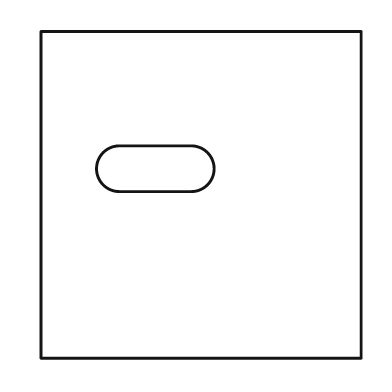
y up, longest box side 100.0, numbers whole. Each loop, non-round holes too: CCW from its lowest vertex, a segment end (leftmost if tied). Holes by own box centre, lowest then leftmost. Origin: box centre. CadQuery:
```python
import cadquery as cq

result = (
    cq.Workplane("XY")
    .moveTo(-49.0, -50.0)
    .lineTo(49.0, -50.0)
    .lineTo(49.0, 50.0)
    .lineTo(-49.0, 50.0)
    .close()
    .moveTo(-25.0, 1.0)
    .lineTo(-3.0, 1.0)
    .threePointArc((4.0, 8.0), (-3.0, 15.0))
    .lineTo(-25.0, 15.0)
    .threePointArc((-32.0, 8.0), (-25.0, 1.0))
    .close()
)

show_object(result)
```